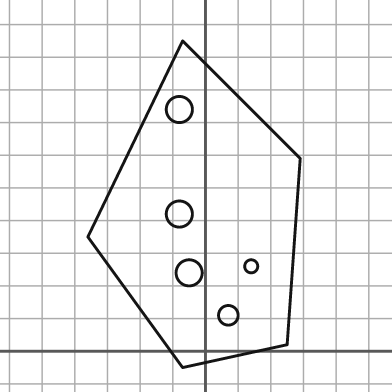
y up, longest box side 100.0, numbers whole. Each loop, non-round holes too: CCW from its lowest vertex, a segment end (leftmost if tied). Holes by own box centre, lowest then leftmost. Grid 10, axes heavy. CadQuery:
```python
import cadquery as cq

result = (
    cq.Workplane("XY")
    .moveTo(-7.0, -5.0)
    .lineTo(25.0, 2.0)
    .lineTo(29.0, 59.0)
    .lineTo(-7.0, 95.0)
    .lineTo(-36.0, 35.0)
    .close()
    .moveTo(7.0, 11.0)
    .circle(3.0)
    .moveTo(-5.0, 24.0)
    .circle(4.0)
    .moveTo(14.0, 26.0)
    .circle(2.0)
    .moveTo(-8.0, 42.0)
    .circle(4.0)
    .moveTo(-8.0, 74.0)
    .circle(4.0)
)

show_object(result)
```